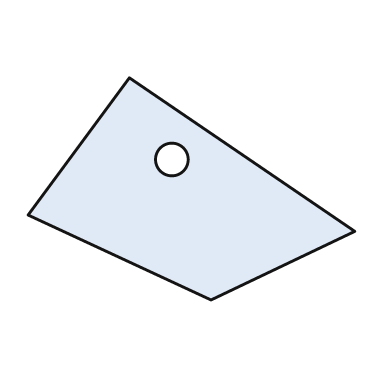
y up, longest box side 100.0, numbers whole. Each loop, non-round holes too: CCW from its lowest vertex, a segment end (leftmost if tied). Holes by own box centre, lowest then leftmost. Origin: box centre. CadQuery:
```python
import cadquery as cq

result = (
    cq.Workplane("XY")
    .moveTo(6.0, -34.0)
    .lineTo(50.0, -13.0)
    .lineTo(-19.0, 34.0)
    .lineTo(-50.0, -8.0)
    .close()
    .moveTo(-6.0, 9.0)
    .circle(5.0)
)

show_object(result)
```